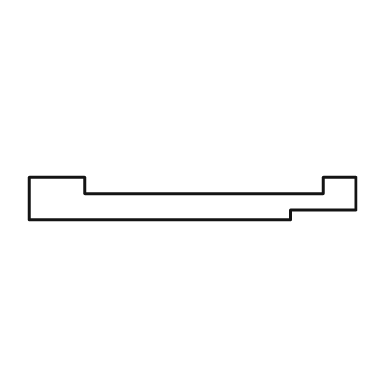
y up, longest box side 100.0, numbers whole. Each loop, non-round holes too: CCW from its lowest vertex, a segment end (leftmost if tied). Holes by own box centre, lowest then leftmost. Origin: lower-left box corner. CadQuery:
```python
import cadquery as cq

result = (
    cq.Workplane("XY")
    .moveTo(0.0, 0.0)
    .lineTo(80.0, 0.0)
    .lineTo(80.0, 3.0)
    .lineTo(100.0, 3.0)
    .lineTo(100.0, 13.0)
    .lineTo(90.0, 13.0)
    .lineTo(90.0, 8.0)
    .lineTo(17.0, 8.0)
    .lineTo(17.0, 13.0)
    .lineTo(0.0, 13.0)
    .close()
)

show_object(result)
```